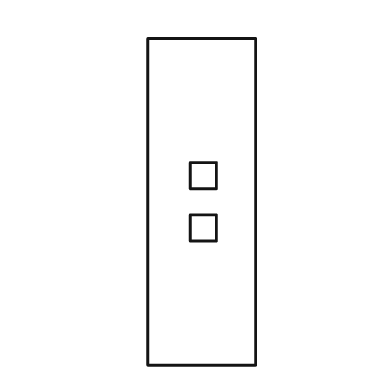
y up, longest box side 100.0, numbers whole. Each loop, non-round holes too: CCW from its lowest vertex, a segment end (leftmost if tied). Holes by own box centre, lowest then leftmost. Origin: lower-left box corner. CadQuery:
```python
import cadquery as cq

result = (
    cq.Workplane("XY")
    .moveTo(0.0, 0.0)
    .lineTo(33.0, 0.0)
    .lineTo(33.0, 100.0)
    .lineTo(0.0, 100.0)
    .close()
    .moveTo(13.0, 38.0)
    .lineTo(21.0, 38.0)
    .lineTo(21.0, 46.0)
    .lineTo(13.0, 46.0)
    .close()
    .moveTo(13.0, 54.0)
    .lineTo(21.0, 54.0)
    .lineTo(21.0, 62.0)
    .lineTo(13.0, 62.0)
    .close()
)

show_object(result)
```